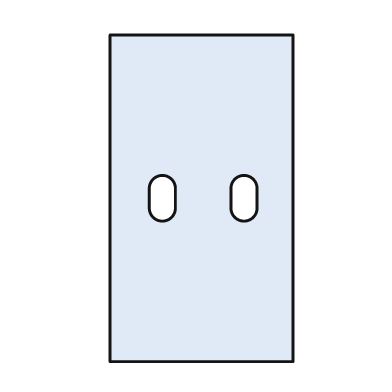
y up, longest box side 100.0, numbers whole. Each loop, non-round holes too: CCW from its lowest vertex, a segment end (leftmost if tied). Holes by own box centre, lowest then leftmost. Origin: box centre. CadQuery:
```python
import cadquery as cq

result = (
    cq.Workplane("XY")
    .moveTo(-28.0, -50.0)
    .lineTo(28.0, -50.0)
    .lineTo(28.0, 50.0)
    .lineTo(-28.0, 50.0)
    .close()
    .moveTo(-16.0, -3.0)
    .threePointArc((-12.0, -7.0), (-8.0, -3.0))
    .lineTo(-8.0, 3.0)
    .threePointArc((-12.0, 7.0), (-16.0, 3.0))
    .close()
    .moveTo(9.0, -3.0)
    .threePointArc((13.0, -7.0), (17.0, -3.0))
    .lineTo(17.0, 3.0)
    .threePointArc((13.0, 7.0), (9.0, 3.0))
    .close()
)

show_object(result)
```